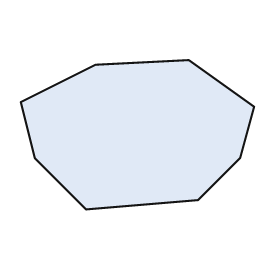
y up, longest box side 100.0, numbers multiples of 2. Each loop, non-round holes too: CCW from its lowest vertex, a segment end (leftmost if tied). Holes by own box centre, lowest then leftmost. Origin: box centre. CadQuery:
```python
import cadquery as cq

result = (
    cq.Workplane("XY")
    .moveTo(-22.0, -32.0)
    .lineTo(26.0, -28.0)
    .lineTo(44.0, -10.0)
    .lineTo(50.0, 12.0)
    .lineTo(22.0, 32.0)
    .lineTo(-18.0, 30.0)
    .lineTo(-50.0, 14.0)
    .lineTo(-44.0, -10.0)
    .close()
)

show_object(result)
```